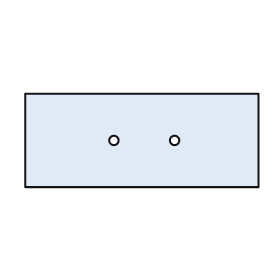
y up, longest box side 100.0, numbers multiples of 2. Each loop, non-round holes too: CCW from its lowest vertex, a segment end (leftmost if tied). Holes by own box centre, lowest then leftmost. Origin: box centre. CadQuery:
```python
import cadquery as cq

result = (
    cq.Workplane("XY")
    .moveTo(-50.0, -20.0)
    .lineTo(50.0, -20.0)
    .lineTo(50.0, 20.0)
    .lineTo(-50.0, 20.0)
    .close()
    .moveTo(-12.0, 0.0)
    .circle(2.0)
    .moveTo(14.0, 0.0)
    .circle(2.0)
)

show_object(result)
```